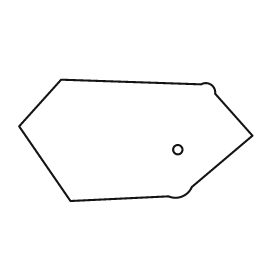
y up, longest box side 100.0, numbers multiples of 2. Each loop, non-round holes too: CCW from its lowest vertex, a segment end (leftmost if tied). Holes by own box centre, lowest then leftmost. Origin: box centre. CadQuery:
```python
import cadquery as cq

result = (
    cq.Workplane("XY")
    .moveTo(-28.0, -26.0)
    .lineTo(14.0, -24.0)
    .threePointArc((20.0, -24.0), (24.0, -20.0))
    .lineTo(50.0, 2.0)
    .lineTo(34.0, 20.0)
    .threePointArc((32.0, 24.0), (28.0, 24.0))
    .lineTo(-32.0, 26.0)
    .lineTo(-50.0, 6.0)
    .close()
    .moveTo(18.0, -4.0)
    .circle(2.0)
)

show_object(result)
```